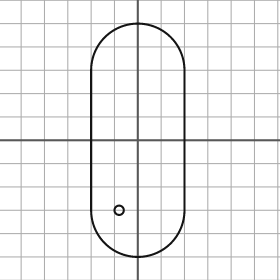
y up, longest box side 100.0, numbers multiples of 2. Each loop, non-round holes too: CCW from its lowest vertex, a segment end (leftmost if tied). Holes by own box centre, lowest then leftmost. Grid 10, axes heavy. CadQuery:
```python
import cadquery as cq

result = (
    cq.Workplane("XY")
    .moveTo(-20.0, -30.0)
    .threePointArc((0.0, -50.0), (20.0, -30.0))
    .lineTo(20.0, 30.0)
    .threePointArc((0.0, 50.0), (-20.0, 30.0))
    .close()
    .moveTo(-8.0, -30.0)
    .circle(2.0)
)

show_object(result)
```